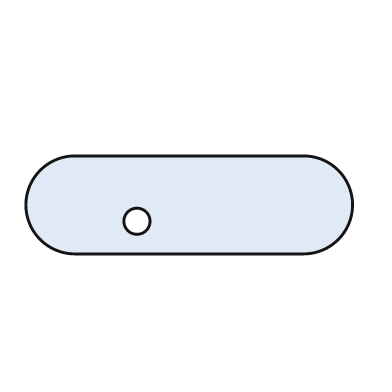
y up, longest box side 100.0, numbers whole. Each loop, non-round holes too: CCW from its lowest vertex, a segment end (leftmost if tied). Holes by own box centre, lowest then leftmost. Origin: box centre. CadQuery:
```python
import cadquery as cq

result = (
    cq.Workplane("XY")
    .moveTo(-35.0, -15.0)
    .lineTo(35.0, -15.0)
    .threePointArc((50.0, 0.0), (35.0, 15.0))
    .lineTo(-35.0, 15.0)
    .threePointArc((-50.0, 0.0), (-35.0, -15.0))
    .close()
    .moveTo(-16.0, -5.0)
    .circle(4.0)
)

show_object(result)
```